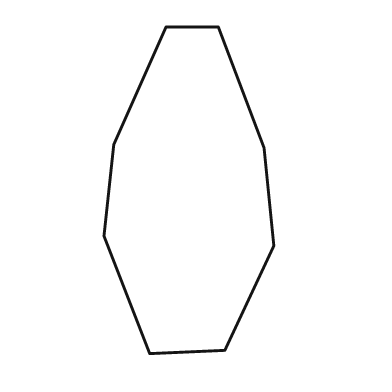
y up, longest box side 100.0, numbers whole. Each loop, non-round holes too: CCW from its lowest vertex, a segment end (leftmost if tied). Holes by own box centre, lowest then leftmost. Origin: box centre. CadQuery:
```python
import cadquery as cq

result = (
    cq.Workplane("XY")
    .moveTo(-12.0, -50.0)
    .lineTo(11.0, -49.0)
    .lineTo(26.0, -17.0)
    .lineTo(23.0, 13.0)
    .lineTo(9.0, 50.0)
    .lineTo(-7.0, 50.0)
    .lineTo(-23.0, 14.0)
    .lineTo(-26.0, -14.0)
    .close()
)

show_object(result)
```